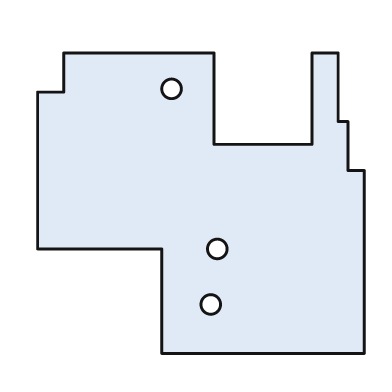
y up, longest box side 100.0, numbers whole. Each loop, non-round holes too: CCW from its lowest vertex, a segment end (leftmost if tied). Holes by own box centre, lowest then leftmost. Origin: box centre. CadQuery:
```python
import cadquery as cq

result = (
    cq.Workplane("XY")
    .moveTo(-12.0, -46.0)
    .lineTo(50.0, -46.0)
    .lineTo(50.0, 10.0)
    .lineTo(45.0, 10.0)
    .lineTo(45.0, 25.0)
    .lineTo(42.0, 25.0)
    .lineTo(42.0, 46.0)
    .lineTo(34.0, 46.0)
    .lineTo(34.0, 18.0)
    .lineTo(4.0, 18.0)
    .lineTo(4.0, 46.0)
    .lineTo(-42.0, 46.0)
    .lineTo(-42.0, 34.0)
    .lineTo(-50.0, 34.0)
    .lineTo(-50.0, -14.0)
    .lineTo(-12.0, -14.0)
    .close()
    .moveTo(3.0, -31.0)
    .circle(3.0)
    .moveTo(5.0, -14.0)
    .circle(3.0)
    .moveTo(-9.0, 35.0)
    .circle(3.0)
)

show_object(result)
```